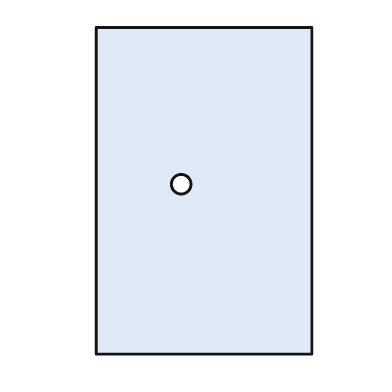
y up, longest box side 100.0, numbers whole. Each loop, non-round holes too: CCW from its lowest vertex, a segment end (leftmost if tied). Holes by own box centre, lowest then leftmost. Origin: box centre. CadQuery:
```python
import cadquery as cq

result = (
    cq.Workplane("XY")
    .moveTo(-33.0, -50.0)
    .lineTo(33.0, -50.0)
    .lineTo(33.0, 50.0)
    .lineTo(-33.0, 50.0)
    .close()
    .moveTo(-7.0, 2.0)
    .circle(3.0)
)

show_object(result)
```